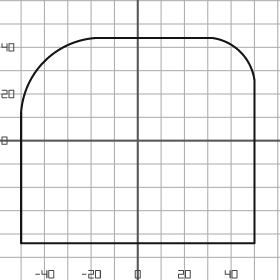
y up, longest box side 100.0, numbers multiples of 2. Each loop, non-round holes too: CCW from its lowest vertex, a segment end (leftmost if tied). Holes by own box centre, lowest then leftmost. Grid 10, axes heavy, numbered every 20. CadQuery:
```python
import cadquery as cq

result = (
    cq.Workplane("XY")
    .moveTo(-50.0, -44.0)
    .lineTo(50.0, -44.0)
    .lineTo(50.0, 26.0)
    .threePointArc((44.0, 38.0), (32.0, 44.0))
    .lineTo(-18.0, 44.0)
    .threePointArc((-40.0, 34.0), (-50.0, 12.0))
    .close()
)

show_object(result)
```